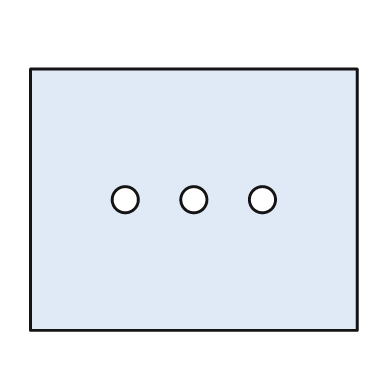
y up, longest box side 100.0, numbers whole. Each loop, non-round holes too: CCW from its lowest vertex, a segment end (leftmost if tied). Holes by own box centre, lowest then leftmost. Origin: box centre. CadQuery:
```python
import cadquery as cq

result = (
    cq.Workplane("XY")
    .moveTo(-50.0, -40.0)
    .lineTo(50.0, -40.0)
    .lineTo(50.0, 40.0)
    .lineTo(-50.0, 40.0)
    .close()
    .moveTo(-21.0, 0.0)
    .circle(4.0)
    .moveTo(0.0, 0.0)
    .circle(4.0)
    .moveTo(21.0, 0.0)
    .circle(4.0)
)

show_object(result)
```